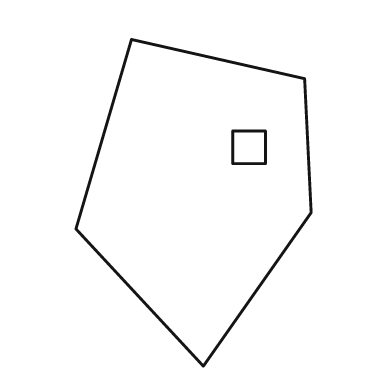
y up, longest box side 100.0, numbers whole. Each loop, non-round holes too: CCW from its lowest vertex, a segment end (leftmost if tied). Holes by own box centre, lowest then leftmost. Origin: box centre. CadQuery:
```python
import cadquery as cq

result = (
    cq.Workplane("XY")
    .moveTo(3.0, -50.0)
    .lineTo(36.0, -3.0)
    .lineTo(34.0, 38.0)
    .lineTo(-19.0, 50.0)
    .lineTo(-36.0, -8.0)
    .close()
    .moveTo(12.0, 12.0)
    .lineTo(22.0, 12.0)
    .lineTo(22.0, 22.0)
    .lineTo(12.0, 22.0)
    .close()
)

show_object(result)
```